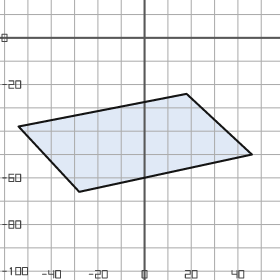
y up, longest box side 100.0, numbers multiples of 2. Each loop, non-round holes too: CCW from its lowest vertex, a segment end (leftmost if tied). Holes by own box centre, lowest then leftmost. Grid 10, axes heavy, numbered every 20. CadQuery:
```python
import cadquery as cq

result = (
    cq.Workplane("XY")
    .moveTo(-28.0, -66.0)
    .lineTo(46.0, -50.0)
    .lineTo(18.0, -24.0)
    .lineTo(-54.0, -38.0)
    .close()
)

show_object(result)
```